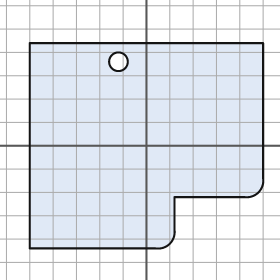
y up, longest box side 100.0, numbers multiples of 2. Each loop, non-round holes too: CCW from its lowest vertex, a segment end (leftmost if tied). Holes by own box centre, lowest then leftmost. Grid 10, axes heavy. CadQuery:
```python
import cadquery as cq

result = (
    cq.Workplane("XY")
    .moveTo(-50.0, -44.0)
    .lineTo(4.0, -44.0)
    .threePointArc((10.0, -42.0), (12.0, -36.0))
    .lineTo(12.0, -22.0)
    .lineTo(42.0, -22.0)
    .threePointArc((48.0, -20.0), (50.0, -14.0))
    .lineTo(50.0, 44.0)
    .lineTo(-50.0, 44.0)
    .close()
    .moveTo(-12.0, 36.0)
    .circle(4.0)
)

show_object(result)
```